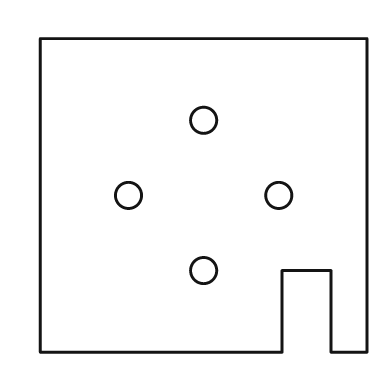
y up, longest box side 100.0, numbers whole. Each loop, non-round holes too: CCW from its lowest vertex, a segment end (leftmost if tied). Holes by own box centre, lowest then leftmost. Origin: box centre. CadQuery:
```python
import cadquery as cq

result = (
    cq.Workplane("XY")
    .moveTo(-50.0, -48.0)
    .lineTo(24.0, -48.0)
    .lineTo(24.0, -23.0)
    .lineTo(39.0, -23.0)
    .lineTo(39.0, -48.0)
    .lineTo(50.0, -48.0)
    .lineTo(50.0, 48.0)
    .lineTo(-50.0, 48.0)
    .close()
    .moveTo(0.0, -23.0)
    .circle(4.0)
    .moveTo(-23.0, 0.0)
    .circle(4.0)
    .moveTo(23.0, 0.0)
    .circle(4.0)
    .moveTo(0.0, 23.0)
    .circle(4.0)
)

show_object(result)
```